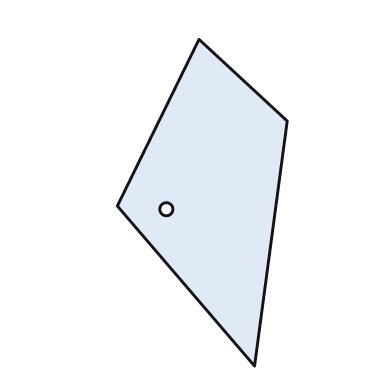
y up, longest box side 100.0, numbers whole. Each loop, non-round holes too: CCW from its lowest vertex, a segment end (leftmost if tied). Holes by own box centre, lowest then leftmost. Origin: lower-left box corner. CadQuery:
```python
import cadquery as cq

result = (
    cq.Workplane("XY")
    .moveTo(42.0, 0.0)
    .lineTo(52.0, 75.0)
    .lineTo(25.0, 100.0)
    .lineTo(0.0, 49.0)
    .close()
    .moveTo(15.0, 48.0)
    .circle(2.0)
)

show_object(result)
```